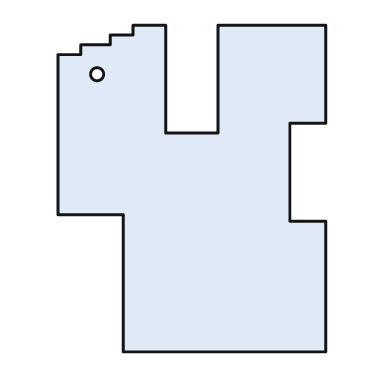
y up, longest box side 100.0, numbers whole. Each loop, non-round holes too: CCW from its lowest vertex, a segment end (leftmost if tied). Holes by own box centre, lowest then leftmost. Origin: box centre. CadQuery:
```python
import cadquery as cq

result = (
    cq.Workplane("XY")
    .moveTo(-21.0, -50.0)
    .lineTo(41.0, -50.0)
    .lineTo(41.0, -10.0)
    .lineTo(30.0, -10.0)
    .lineTo(30.0, 20.0)
    .lineTo(41.0, 20.0)
    .lineTo(41.0, 50.0)
    .lineTo(8.0, 50.0)
    .lineTo(8.0, 17.0)
    .lineTo(-8.0, 17.0)
    .lineTo(-8.0, 50.0)
    .lineTo(-18.0, 50.0)
    .lineTo(-18.0, 47.0)
    .lineTo(-25.0, 47.0)
    .lineTo(-25.0, 44.0)
    .lineTo(-34.0, 44.0)
    .lineTo(-34.0, 41.0)
    .lineTo(-41.0, 41.0)
    .lineTo(-41.0, -8.0)
    .lineTo(-21.0, -8.0)
    .close()
    .moveTo(-29.0, 35.0)
    .circle(2.0)
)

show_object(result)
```